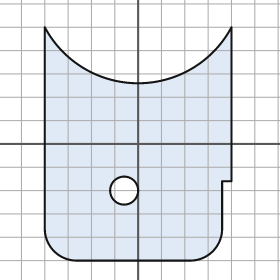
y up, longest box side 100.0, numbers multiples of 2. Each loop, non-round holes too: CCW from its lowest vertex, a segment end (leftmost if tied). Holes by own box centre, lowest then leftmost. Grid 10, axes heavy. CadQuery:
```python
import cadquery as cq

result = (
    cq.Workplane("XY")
    .moveTo(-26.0, -50.0)
    .lineTo(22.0, -50.0)
    .threePointArc((32.0, -46.0), (36.0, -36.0))
    .lineTo(36.0, -16.0)
    .lineTo(40.0, -16.0)
    .lineTo(40.0, 50.0)
    .threePointArc((0.0, 26.0), (-40.0, 50.0))
    .lineTo(-40.0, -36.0)
    .threePointArc((-36.0, -46.0), (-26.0, -50.0))
    .close()
    .moveTo(-6.0, -20.0)
    .circle(6.0)
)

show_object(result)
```